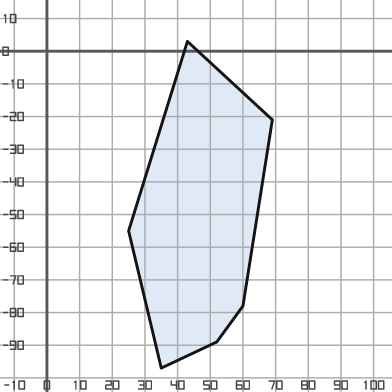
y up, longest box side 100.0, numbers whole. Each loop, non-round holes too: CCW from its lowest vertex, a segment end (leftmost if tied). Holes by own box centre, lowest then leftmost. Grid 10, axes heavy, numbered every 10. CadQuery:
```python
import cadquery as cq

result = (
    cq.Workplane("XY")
    .moveTo(35.0, -97.0)
    .lineTo(52.0, -89.0)
    .lineTo(60.0, -78.0)
    .lineTo(69.0, -21.0)
    .lineTo(43.0, 3.0)
    .lineTo(25.0, -55.0)
    .close()
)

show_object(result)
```